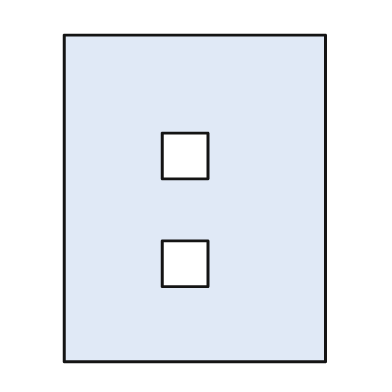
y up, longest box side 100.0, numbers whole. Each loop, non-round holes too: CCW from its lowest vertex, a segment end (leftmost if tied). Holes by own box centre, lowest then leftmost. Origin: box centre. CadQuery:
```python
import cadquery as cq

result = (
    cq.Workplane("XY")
    .moveTo(-40.0, -50.0)
    .lineTo(40.0, -50.0)
    .lineTo(40.0, 50.0)
    .lineTo(-40.0, 50.0)
    .close()
    .moveTo(-10.0, -27.0)
    .lineTo(4.0, -27.0)
    .lineTo(4.0, -13.0)
    .lineTo(-10.0, -13.0)
    .close()
    .moveTo(-10.0, 6.0)
    .lineTo(4.0, 6.0)
    .lineTo(4.0, 20.0)
    .lineTo(-10.0, 20.0)
    .close()
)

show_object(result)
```